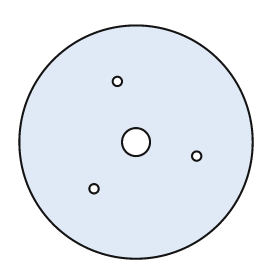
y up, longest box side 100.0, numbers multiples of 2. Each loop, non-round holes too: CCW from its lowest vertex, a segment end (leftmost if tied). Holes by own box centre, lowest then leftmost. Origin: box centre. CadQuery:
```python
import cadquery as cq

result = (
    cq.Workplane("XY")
    .moveTo(0.0, 0.0)
    .circle(50.0)
    .moveTo(-18.0, -20.0)
    .circle(2.0)
    .moveTo(26.0, -6.0)
    .circle(2.0)
    .moveTo(0.0, 0.0)
    .circle(6.0)
    .moveTo(-8.0, 26.0)
    .circle(2.0)
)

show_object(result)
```